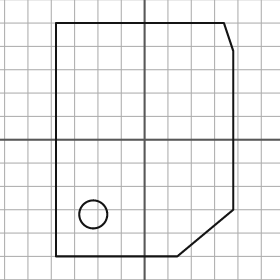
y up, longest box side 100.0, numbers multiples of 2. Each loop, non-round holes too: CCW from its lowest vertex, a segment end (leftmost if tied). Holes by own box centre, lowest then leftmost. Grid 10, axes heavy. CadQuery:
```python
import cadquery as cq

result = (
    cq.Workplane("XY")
    .moveTo(-38.0, -50.0)
    .lineTo(14.0, -50.0)
    .lineTo(38.0, -30.0)
    .lineTo(38.0, 38.0)
    .lineTo(34.0, 50.0)
    .lineTo(-38.0, 50.0)
    .close()
    .moveTo(-22.0, -32.0)
    .circle(6.0)
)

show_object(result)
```